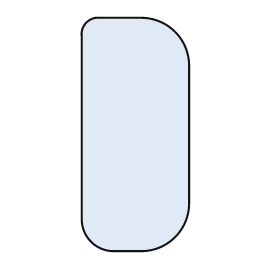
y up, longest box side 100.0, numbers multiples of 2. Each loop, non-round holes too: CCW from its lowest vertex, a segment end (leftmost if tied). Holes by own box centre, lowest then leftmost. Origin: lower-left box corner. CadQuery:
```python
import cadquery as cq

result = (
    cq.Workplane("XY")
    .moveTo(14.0, 0.0)
    .lineTo(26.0, 0.0)
    .threePointArc((40.0, 6.0), (46.0, 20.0))
    .lineTo(46.0, 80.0)
    .threePointArc((40.0, 94.0), (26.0, 100.0))
    .lineTo(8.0, 100.0)
    .threePointArc((2.0, 98.0), (0.0, 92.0))
    .lineTo(0.0, 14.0)
    .threePointArc((4.0, 4.0), (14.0, 0.0))
    .close()
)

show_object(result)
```